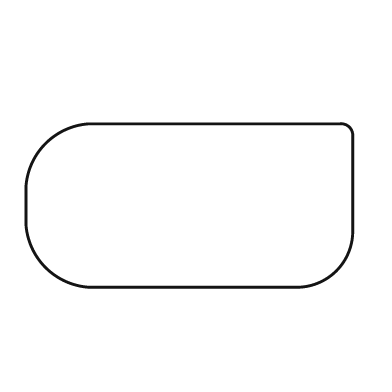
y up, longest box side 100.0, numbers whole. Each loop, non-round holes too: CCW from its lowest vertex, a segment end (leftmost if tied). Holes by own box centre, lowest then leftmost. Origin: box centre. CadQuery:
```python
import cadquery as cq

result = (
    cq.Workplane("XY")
    .moveTo(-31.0, -25.0)
    .lineTo(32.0, -25.0)
    .threePointArc((45.0, -20.0), (50.0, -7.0))
    .lineTo(50.0, 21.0)
    .threePointArc((49.0, 24.0), (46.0, 25.0))
    .lineTo(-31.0, 25.0)
    .threePointArc((-44.0, 19.0), (-50.0, 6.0))
    .lineTo(-50.0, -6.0)
    .threePointArc((-44.0, -19.0), (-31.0, -25.0))
    .close()
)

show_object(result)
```